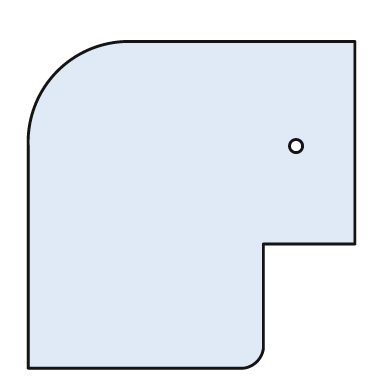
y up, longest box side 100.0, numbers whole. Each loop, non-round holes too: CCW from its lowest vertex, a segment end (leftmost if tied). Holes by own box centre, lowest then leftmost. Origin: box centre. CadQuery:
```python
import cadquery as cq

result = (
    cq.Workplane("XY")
    .moveTo(-50.0, -50.0)
    .lineTo(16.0, -50.0)
    .threePointArc((20.0, -48.0), (22.0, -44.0))
    .lineTo(22.0, -12.0)
    .lineTo(50.0, -12.0)
    .lineTo(50.0, 50.0)
    .lineTo(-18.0, 50.0)
    .threePointArc((-41.0, 41.0), (-50.0, 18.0))
    .close()
    .moveTo(32.0, 18.0)
    .circle(2.0)
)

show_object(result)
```